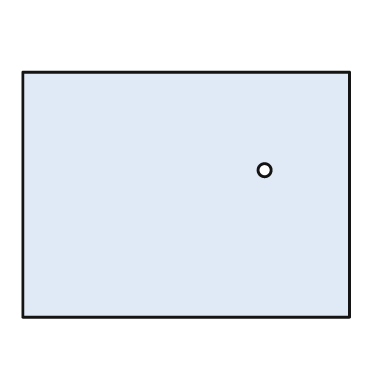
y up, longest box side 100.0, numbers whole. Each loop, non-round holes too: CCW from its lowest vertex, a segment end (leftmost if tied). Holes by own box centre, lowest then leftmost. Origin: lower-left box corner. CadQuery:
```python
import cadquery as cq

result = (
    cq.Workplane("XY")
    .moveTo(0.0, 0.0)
    .lineTo(100.0, 0.0)
    .lineTo(100.0, 75.0)
    .lineTo(0.0, 75.0)
    .close()
    .moveTo(74.0, 45.0)
    .circle(2.0)
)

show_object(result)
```